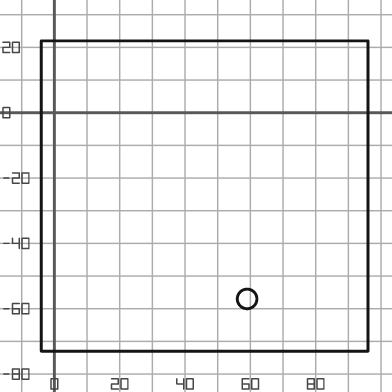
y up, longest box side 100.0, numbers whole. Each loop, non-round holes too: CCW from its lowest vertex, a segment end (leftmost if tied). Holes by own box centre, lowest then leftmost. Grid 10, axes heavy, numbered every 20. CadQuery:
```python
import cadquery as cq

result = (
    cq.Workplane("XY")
    .moveTo(-4.0, -73.0)
    .lineTo(96.0, -73.0)
    .lineTo(96.0, 22.0)
    .lineTo(-4.0, 22.0)
    .close()
    .moveTo(59.0, -57.0)
    .circle(3.0)
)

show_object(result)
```